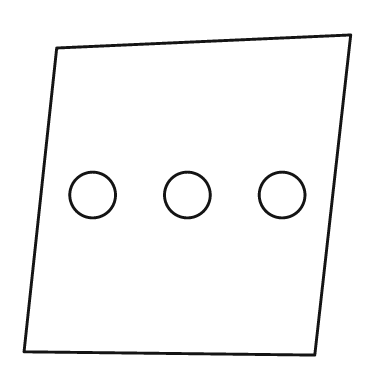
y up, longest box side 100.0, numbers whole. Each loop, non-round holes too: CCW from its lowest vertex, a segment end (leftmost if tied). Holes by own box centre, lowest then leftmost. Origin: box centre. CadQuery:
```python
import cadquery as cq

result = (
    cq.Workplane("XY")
    .moveTo(39.0, -49.0)
    .lineTo(50.0, 49.0)
    .lineTo(-40.0, 45.0)
    .lineTo(-50.0, -48.0)
    .close()
    .moveTo(-29.0, 0.0)
    .circle(7.0)
    .moveTo(0.0, 0.0)
    .circle(7.0)
    .moveTo(29.0, 0.0)
    .circle(7.0)
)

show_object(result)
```